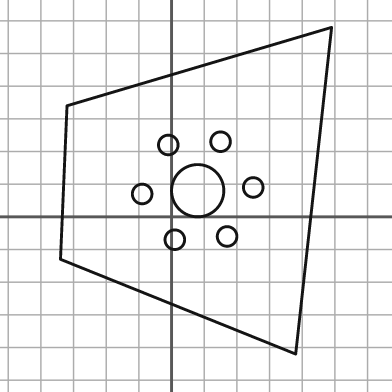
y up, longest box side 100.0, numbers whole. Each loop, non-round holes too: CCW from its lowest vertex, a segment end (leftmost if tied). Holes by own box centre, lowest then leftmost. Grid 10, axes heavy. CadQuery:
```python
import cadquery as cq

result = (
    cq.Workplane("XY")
    .moveTo(38.0, -42.0)
    .lineTo(49.0, 58.0)
    .lineTo(-32.0, 34.0)
    .lineTo(-34.0, -13.0)
    .close()
    .moveTo(1.0, -7.0)
    .circle(3.0)
    .moveTo(17.0, -6.0)
    .circle(3.0)
    .moveTo(-9.0, 7.0)
    .circle(3.0)
    .moveTo(8.0, 8.0)
    .circle(8.0)
    .moveTo(25.0, 9.0)
    .circle(3.0)
    .moveTo(-1.0, 22.0)
    .circle(3.0)
    .moveTo(15.0, 23.0)
    .circle(3.0)
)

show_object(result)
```